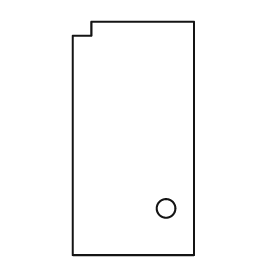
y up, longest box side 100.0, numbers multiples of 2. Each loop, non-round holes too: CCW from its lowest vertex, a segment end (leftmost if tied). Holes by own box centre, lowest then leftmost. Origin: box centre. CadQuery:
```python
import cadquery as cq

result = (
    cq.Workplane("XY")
    .moveTo(-26.0, -50.0)
    .lineTo(26.0, -50.0)
    .lineTo(26.0, 50.0)
    .lineTo(-18.0, 50.0)
    .lineTo(-18.0, 44.0)
    .lineTo(-26.0, 44.0)
    .close()
    .moveTo(14.0, -30.0)
    .circle(4.0)
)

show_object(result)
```